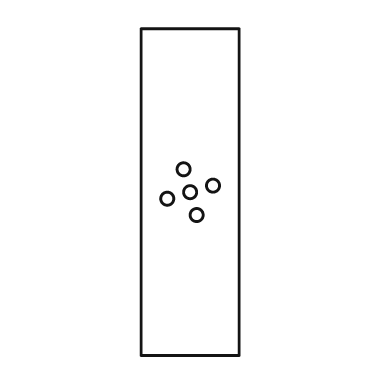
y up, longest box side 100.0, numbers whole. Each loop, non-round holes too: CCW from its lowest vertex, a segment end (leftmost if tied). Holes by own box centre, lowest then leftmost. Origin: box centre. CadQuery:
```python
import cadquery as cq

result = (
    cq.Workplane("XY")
    .moveTo(-15.0, -50.0)
    .lineTo(15.0, -50.0)
    .lineTo(15.0, 50.0)
    .lineTo(-15.0, 50.0)
    .close()
    .moveTo(2.0, -7.0)
    .circle(2.0)
    .moveTo(-7.0, -2.0)
    .circle(2.0)
    .moveTo(0.0, 0.0)
    .circle(2.0)
    .moveTo(7.0, 2.0)
    .circle(2.0)
    .moveTo(-2.0, 7.0)
    .circle(2.0)
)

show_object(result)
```